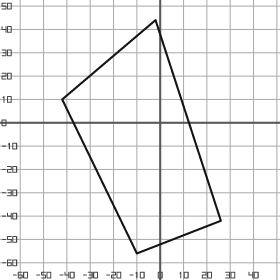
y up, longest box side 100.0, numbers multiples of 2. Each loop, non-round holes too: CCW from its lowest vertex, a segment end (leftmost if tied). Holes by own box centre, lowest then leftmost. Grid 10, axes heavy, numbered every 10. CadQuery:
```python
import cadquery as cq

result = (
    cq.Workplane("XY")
    .moveTo(-10.0, -56.0)
    .lineTo(26.0, -42.0)
    .lineTo(-2.0, 44.0)
    .lineTo(-42.0, 10.0)
    .close()
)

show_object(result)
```